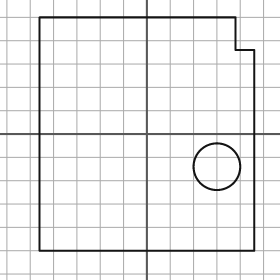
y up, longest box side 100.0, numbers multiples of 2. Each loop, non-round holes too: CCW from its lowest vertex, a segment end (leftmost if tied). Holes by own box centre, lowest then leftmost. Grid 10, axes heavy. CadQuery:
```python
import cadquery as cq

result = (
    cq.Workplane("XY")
    .moveTo(-46.0, -50.0)
    .lineTo(46.0, -50.0)
    .lineTo(46.0, 36.0)
    .lineTo(38.0, 36.0)
    .lineTo(38.0, 50.0)
    .lineTo(-46.0, 50.0)
    .close()
    .moveTo(30.0, -14.0)
    .circle(10.0)
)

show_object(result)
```